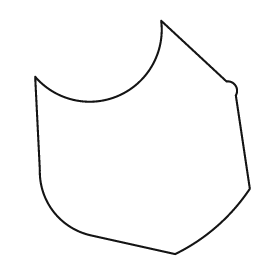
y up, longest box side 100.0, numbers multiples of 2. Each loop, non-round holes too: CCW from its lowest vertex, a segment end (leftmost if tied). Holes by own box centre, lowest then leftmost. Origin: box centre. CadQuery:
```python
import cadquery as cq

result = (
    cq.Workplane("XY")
    .moveTo(14.0, -50.0)
    .threePointArc((32.0, -38.0), (46.0, -22.0))
    .lineTo(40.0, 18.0)
    .threePointArc((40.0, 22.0), (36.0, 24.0))
    .lineTo(8.0, 50.0)
    .threePointArc((-10.0, 18.0), (-46.0, 26.0))
    .lineTo(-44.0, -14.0)
    .threePointArc((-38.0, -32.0), (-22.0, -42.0))
    .close()
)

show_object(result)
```